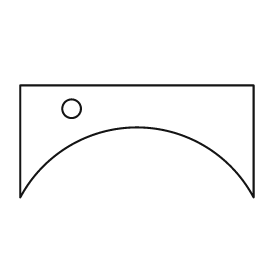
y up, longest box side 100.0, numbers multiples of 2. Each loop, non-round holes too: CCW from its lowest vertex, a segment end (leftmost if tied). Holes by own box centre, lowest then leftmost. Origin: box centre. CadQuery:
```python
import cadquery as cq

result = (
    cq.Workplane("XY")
    .moveTo(-50.0, -24.0)
    .threePointArc((0.0, 6.0), (50.0, -24.0))
    .lineTo(50.0, 24.0)
    .lineTo(-50.0, 24.0)
    .close()
    .moveTo(-28.0, 14.0)
    .circle(4.0)
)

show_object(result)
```